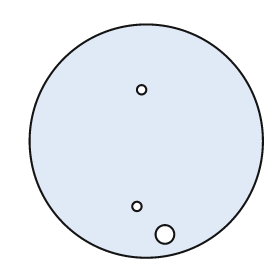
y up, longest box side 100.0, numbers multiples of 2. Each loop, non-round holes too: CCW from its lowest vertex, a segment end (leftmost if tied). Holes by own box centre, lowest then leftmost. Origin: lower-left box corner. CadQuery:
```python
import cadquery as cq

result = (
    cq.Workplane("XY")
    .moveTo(50.0, 50.0)
    .circle(50.0)
    .moveTo(58.0, 10.0)
    .circle(4.0)
    .moveTo(46.0, 22.0)
    .circle(2.0)
    .moveTo(48.0, 72.0)
    .circle(2.0)
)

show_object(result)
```